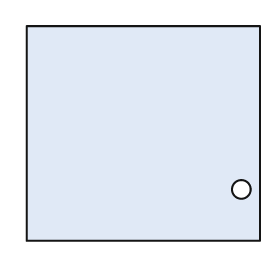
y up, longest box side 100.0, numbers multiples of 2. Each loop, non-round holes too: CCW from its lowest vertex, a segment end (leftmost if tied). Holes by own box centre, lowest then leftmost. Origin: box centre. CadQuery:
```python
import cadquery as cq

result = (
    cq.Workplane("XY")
    .moveTo(-50.0, -46.0)
    .lineTo(50.0, -46.0)
    .lineTo(50.0, 46.0)
    .lineTo(-50.0, 46.0)
    .close()
    .moveTo(42.0, -24.0)
    .circle(4.0)
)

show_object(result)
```